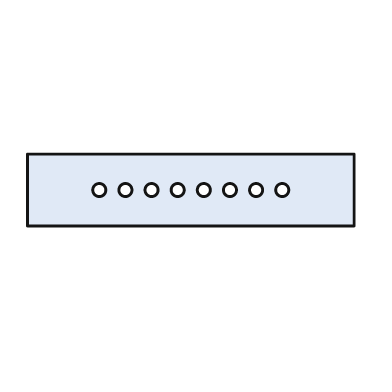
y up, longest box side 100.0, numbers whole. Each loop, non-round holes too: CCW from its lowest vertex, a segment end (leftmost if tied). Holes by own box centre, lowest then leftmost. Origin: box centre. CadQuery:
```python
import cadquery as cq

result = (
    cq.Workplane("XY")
    .moveTo(-50.0, -11.0)
    .lineTo(50.0, -11.0)
    .lineTo(50.0, 11.0)
    .lineTo(-50.0, 11.0)
    .close()
    .moveTo(-28.0, 0.0)
    .circle(2.0)
    .moveTo(-20.0, 0.0)
    .circle(2.0)
    .moveTo(-12.0, 0.0)
    .circle(2.0)
    .moveTo(-4.0, 0.0)
    .circle(2.0)
    .moveTo(4.0, 0.0)
    .circle(2.0)
    .moveTo(12.0, 0.0)
    .circle(2.0)
    .moveTo(20.0, 0.0)
    .circle(2.0)
    .moveTo(28.0, 0.0)
    .circle(2.0)
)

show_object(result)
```